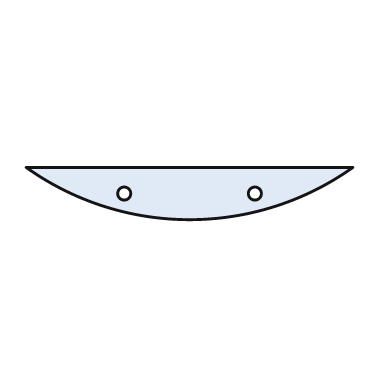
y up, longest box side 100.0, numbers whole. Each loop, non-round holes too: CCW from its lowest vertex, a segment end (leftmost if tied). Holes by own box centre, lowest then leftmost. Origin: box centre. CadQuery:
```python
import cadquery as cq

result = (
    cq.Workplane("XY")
    .moveTo(-50.0, 8.0)
    .threePointArc((0.0, -8.0), (50.0, 8.0))
    .close()
    .moveTo(-20.0, 0.0)
    .circle(2.0)
    .moveTo(20.0, 0.0)
    .circle(2.0)
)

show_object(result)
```